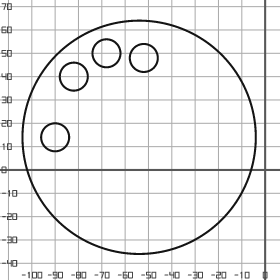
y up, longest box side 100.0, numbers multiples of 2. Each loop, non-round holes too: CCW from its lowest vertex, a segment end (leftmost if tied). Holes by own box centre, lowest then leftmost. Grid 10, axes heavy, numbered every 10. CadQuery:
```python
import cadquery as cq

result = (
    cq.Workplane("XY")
    .moveTo(-54.0, 14.0)
    .circle(50.0)
    .moveTo(-90.0, 14.0)
    .circle(6.0)
    .moveTo(-82.0, 40.0)
    .circle(6.0)
    .moveTo(-52.0, 48.0)
    .circle(6.0)
    .moveTo(-68.0, 50.0)
    .circle(6.0)
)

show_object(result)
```